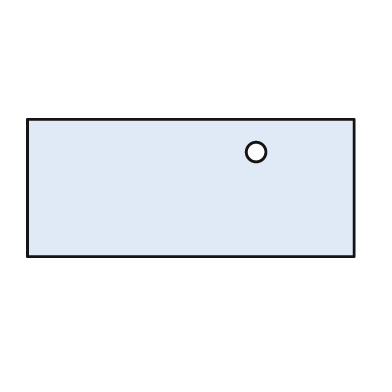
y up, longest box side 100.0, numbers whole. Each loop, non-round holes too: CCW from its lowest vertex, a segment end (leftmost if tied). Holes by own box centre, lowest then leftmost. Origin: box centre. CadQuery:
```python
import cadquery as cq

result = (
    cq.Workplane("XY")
    .moveTo(-50.0, -21.0)
    .lineTo(50.0, -21.0)
    .lineTo(50.0, 21.0)
    .lineTo(-50.0, 21.0)
    .close()
    .moveTo(20.0, 11.0)
    .circle(3.0)
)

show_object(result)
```